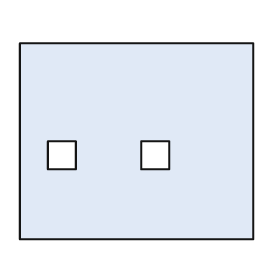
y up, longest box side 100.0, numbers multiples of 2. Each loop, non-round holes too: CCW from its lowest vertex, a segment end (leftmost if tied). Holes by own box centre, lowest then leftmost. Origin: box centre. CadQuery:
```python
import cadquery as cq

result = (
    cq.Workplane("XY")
    .moveTo(-50.0, -42.0)
    .lineTo(50.0, -42.0)
    .lineTo(50.0, 42.0)
    .lineTo(-50.0, 42.0)
    .close()
    .moveTo(-38.0, -12.0)
    .lineTo(-26.0, -12.0)
    .lineTo(-26.0, 0.0)
    .lineTo(-38.0, 0.0)
    .close()
    .moveTo(2.0, -12.0)
    .lineTo(14.0, -12.0)
    .lineTo(14.0, 0.0)
    .lineTo(2.0, 0.0)
    .close()
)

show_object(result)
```